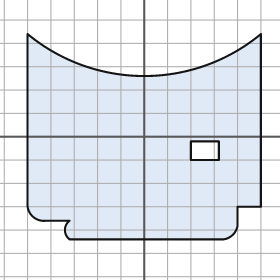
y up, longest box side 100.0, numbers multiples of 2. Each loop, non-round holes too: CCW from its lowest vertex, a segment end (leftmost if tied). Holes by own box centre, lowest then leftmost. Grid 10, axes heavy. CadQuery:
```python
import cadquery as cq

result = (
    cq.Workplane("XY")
    .moveTo(-32.0, -44.0)
    .lineTo(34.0, -44.0)
    .threePointArc((38.0, -42.0), (40.0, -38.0))
    .lineTo(40.0, -30.0)
    .lineTo(50.0, -30.0)
    .lineTo(50.0, 44.0)
    .threePointArc((0.0, 26.0), (-50.0, 44.0))
    .lineTo(-50.0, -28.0)
    .threePointArc((-48.0, -34.0), (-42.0, -36.0))
    .lineTo(-32.0, -36.0)
    .threePointArc((-34.0, -40.0), (-32.0, -44.0))
    .close()
    .moveTo(20.0, -10.0)
    .lineTo(32.0, -10.0)
    .lineTo(32.0, -2.0)
    .lineTo(20.0, -2.0)
    .close()
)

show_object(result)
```